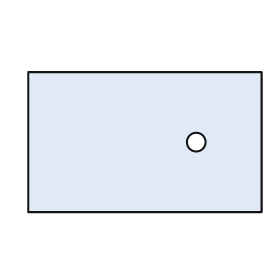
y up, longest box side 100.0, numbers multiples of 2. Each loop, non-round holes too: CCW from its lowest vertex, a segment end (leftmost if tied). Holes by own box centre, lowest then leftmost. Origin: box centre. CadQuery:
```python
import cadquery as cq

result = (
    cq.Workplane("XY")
    .moveTo(-50.0, -30.0)
    .lineTo(50.0, -30.0)
    .lineTo(50.0, 30.0)
    .lineTo(-50.0, 30.0)
    .close()
    .moveTo(22.0, 0.0)
    .circle(4.0)
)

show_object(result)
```